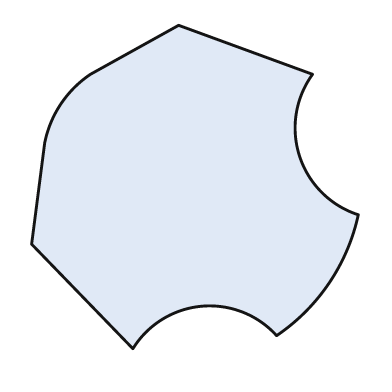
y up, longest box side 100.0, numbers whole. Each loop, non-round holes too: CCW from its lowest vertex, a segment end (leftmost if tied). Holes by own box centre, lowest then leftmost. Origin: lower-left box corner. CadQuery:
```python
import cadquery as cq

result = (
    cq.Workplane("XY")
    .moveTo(31.0, 0.0)
    .threePointArc((52.0, 13.0), (75.0, 4.0))
    .threePointArc((91.0, 20.0), (100.0, 41.0))
    .threePointArc((82.0, 59.0), (86.0, 84.0))
    .lineTo(45.0, 99.0)
    .lineTo(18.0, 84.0)
    .threePointArc((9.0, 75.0), (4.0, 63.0))
    .lineTo(0.0, 32.0)
    .close()
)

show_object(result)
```